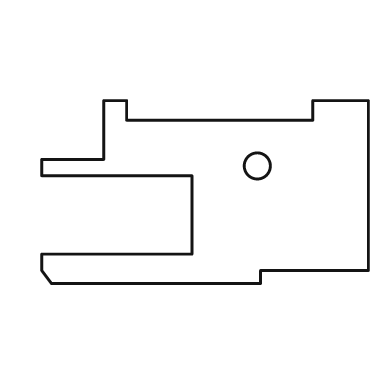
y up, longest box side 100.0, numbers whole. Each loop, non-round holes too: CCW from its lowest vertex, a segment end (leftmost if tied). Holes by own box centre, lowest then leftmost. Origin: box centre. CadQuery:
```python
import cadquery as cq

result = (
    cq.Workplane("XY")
    .moveTo(-47.0, -28.0)
    .lineTo(17.0, -28.0)
    .lineTo(17.0, -24.0)
    .lineTo(50.0, -24.0)
    .lineTo(50.0, 28.0)
    .lineTo(33.0, 28.0)
    .lineTo(33.0, 22.0)
    .lineTo(-24.0, 22.0)
    .lineTo(-24.0, 28.0)
    .lineTo(-31.0, 28.0)
    .lineTo(-31.0, 10.0)
    .lineTo(-50.0, 10.0)
    .lineTo(-50.0, 5.0)
    .lineTo(-4.0, 5.0)
    .lineTo(-4.0, -19.0)
    .lineTo(-50.0, -19.0)
    .lineTo(-50.0, -24.0)
    .close()
    .moveTo(16.0, 8.0)
    .circle(4.0)
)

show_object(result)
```